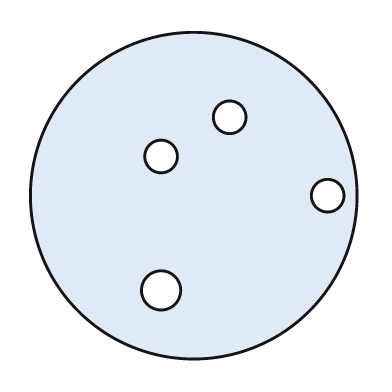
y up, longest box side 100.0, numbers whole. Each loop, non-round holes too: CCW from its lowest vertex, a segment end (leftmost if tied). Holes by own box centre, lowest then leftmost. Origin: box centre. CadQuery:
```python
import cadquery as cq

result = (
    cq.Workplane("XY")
    .moveTo(0.0, 0.0)
    .circle(50.0)
    .moveTo(-10.0, -29.0)
    .circle(6.0)
    .moveTo(41.0, 0.0)
    .circle(5.0)
    .moveTo(-10.0, 12.0)
    .circle(5.0)
    .moveTo(11.0, 24.0)
    .circle(5.0)
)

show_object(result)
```